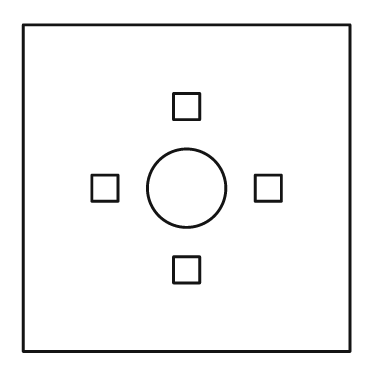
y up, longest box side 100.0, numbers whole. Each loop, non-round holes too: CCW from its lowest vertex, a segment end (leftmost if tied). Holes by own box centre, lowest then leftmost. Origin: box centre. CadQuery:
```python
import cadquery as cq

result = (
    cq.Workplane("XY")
    .moveTo(-50.0, -50.0)
    .lineTo(50.0, -50.0)
    .lineTo(50.0, 50.0)
    .lineTo(-50.0, 50.0)
    .close()
    .moveTo(-4.0, -29.0)
    .lineTo(4.0, -29.0)
    .lineTo(4.0, -21.0)
    .lineTo(-4.0, -21.0)
    .close()
    .moveTo(-29.0, -4.0)
    .lineTo(-21.0, -4.0)
    .lineTo(-21.0, 4.0)
    .lineTo(-29.0, 4.0)
    .close()
    .moveTo(0.0, 0.0)
    .circle(12.0)
    .moveTo(21.0, -4.0)
    .lineTo(29.0, -4.0)
    .lineTo(29.0, 4.0)
    .lineTo(21.0, 4.0)
    .close()
    .moveTo(-4.0, 21.0)
    .lineTo(4.0, 21.0)
    .lineTo(4.0, 29.0)
    .lineTo(-4.0, 29.0)
    .close()
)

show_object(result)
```